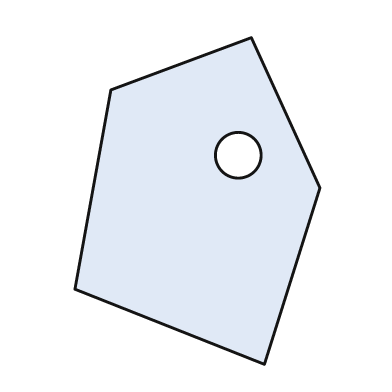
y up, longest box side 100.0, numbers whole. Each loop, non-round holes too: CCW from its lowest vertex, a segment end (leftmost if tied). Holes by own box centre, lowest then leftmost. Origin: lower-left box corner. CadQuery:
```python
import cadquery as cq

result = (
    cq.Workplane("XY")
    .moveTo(58.0, 0.0)
    .lineTo(75.0, 54.0)
    .lineTo(54.0, 100.0)
    .lineTo(11.0, 84.0)
    .lineTo(0.0, 23.0)
    .close()
    .moveTo(50.0, 64.0)
    .circle(7.0)
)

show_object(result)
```